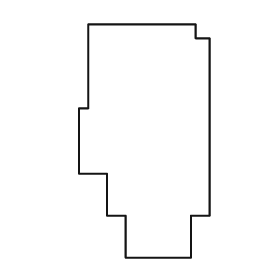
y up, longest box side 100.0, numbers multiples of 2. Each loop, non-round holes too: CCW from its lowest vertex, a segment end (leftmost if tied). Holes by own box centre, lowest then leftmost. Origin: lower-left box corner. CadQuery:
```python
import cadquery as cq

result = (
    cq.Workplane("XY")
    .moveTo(20.0, 0.0)
    .lineTo(48.0, 0.0)
    .lineTo(48.0, 18.0)
    .lineTo(56.0, 18.0)
    .lineTo(56.0, 94.0)
    .lineTo(50.0, 94.0)
    .lineTo(50.0, 100.0)
    .lineTo(4.0, 100.0)
    .lineTo(4.0, 64.0)
    .lineTo(0.0, 64.0)
    .lineTo(0.0, 36.0)
    .lineTo(12.0, 36.0)
    .lineTo(12.0, 18.0)
    .lineTo(20.0, 18.0)
    .close()
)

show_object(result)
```